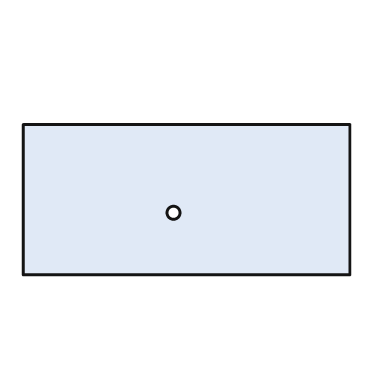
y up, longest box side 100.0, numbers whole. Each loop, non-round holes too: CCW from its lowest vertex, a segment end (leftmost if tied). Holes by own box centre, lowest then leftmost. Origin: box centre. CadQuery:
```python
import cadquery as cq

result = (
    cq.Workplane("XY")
    .moveTo(-50.0, -23.0)
    .lineTo(50.0, -23.0)
    .lineTo(50.0, 23.0)
    .lineTo(-50.0, 23.0)
    .close()
    .moveTo(-4.0, -4.0)
    .circle(2.0)
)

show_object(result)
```